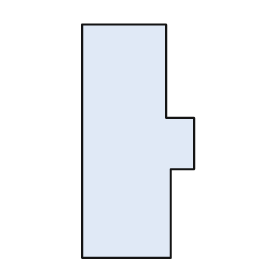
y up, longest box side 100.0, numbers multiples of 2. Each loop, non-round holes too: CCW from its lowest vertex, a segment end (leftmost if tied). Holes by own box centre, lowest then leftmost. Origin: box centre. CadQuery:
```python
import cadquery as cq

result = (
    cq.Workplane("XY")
    .moveTo(-24.0, -50.0)
    .lineTo(14.0, -50.0)
    .lineTo(14.0, -12.0)
    .lineTo(24.0, -12.0)
    .lineTo(24.0, 10.0)
    .lineTo(12.0, 10.0)
    .lineTo(12.0, 50.0)
    .lineTo(-24.0, 50.0)
    .close()
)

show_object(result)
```